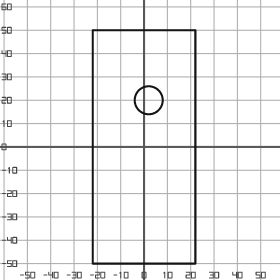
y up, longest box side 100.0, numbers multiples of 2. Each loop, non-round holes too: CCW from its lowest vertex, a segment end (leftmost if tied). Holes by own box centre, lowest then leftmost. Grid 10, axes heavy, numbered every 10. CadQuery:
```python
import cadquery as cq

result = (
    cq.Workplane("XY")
    .moveTo(-22.0, -50.0)
    .lineTo(22.0, -50.0)
    .lineTo(22.0, 50.0)
    .lineTo(-22.0, 50.0)
    .close()
    .moveTo(2.0, 20.0)
    .circle(6.0)
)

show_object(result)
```